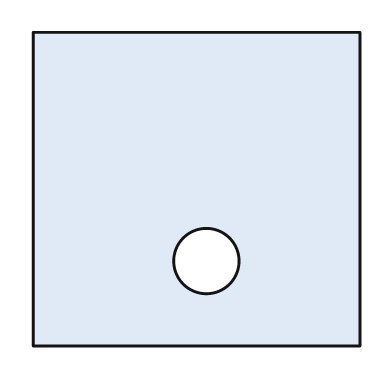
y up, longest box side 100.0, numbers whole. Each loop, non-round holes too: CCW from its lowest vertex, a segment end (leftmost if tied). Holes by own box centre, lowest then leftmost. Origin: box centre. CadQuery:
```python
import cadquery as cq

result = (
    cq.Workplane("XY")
    .moveTo(-50.0, -48.0)
    .lineTo(50.0, -48.0)
    .lineTo(50.0, 48.0)
    .lineTo(-50.0, 48.0)
    .close()
    .moveTo(3.0, -22.0)
    .circle(10.0)
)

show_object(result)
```